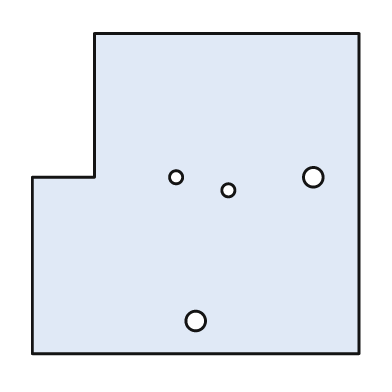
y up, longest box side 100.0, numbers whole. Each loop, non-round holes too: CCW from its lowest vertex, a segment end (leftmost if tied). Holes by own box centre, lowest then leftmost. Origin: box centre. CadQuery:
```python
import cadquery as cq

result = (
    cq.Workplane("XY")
    .moveTo(-50.0, -49.0)
    .lineTo(50.0, -49.0)
    .lineTo(50.0, 49.0)
    .lineTo(-31.0, 49.0)
    .lineTo(-31.0, 5.0)
    .lineTo(-50.0, 5.0)
    .close()
    .moveTo(0.0, -39.0)
    .circle(3.0)
    .moveTo(10.0, 1.0)
    .circle(2.0)
    .moveTo(-6.0, 5.0)
    .circle(2.0)
    .moveTo(36.0, 5.0)
    .circle(3.0)
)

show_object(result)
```